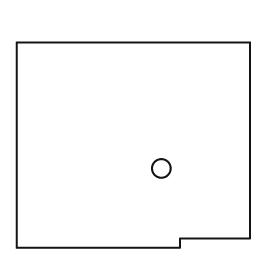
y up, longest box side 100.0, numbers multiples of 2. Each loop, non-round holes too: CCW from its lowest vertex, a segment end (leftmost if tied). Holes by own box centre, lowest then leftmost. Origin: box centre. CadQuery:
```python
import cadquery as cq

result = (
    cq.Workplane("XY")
    .moveTo(-50.0, -44.0)
    .lineTo(20.0, -44.0)
    .lineTo(20.0, -40.0)
    .lineTo(50.0, -40.0)
    .lineTo(50.0, 44.0)
    .lineTo(-50.0, 44.0)
    .close()
    .moveTo(12.0, -10.0)
    .circle(4.0)
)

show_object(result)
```